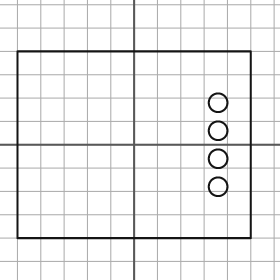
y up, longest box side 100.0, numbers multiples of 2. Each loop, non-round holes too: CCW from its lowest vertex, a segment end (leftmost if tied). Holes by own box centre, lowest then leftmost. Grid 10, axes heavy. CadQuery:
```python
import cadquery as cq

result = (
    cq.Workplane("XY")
    .moveTo(-50.0, -40.0)
    .lineTo(50.0, -40.0)
    .lineTo(50.0, 40.0)
    .lineTo(-50.0, 40.0)
    .close()
    .moveTo(36.0, -18.0)
    .circle(4.0)
    .moveTo(36.0, -6.0)
    .circle(4.0)
    .moveTo(36.0, 6.0)
    .circle(4.0)
    .moveTo(36.0, 18.0)
    .circle(4.0)
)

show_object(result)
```